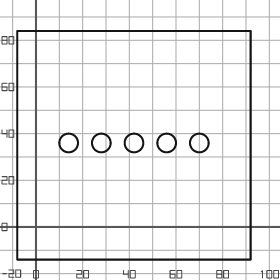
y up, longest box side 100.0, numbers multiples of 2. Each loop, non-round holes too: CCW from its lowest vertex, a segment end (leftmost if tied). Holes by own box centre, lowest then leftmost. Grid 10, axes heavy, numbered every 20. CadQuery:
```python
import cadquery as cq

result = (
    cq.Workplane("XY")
    .moveTo(-8.0, -14.0)
    .lineTo(92.0, -14.0)
    .lineTo(92.0, 84.0)
    .lineTo(-8.0, 84.0)
    .close()
    .moveTo(14.0, 36.0)
    .circle(4.0)
    .moveTo(28.0, 36.0)
    .circle(4.0)
    .moveTo(42.0, 36.0)
    .circle(4.0)
    .moveTo(56.0, 36.0)
    .circle(4.0)
    .moveTo(70.0, 36.0)
    .circle(4.0)
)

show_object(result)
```